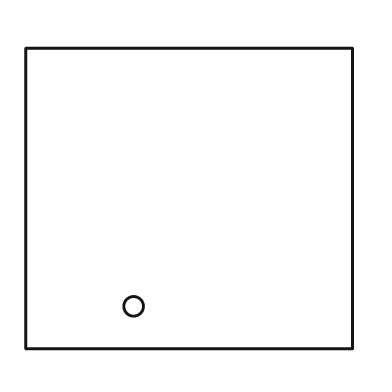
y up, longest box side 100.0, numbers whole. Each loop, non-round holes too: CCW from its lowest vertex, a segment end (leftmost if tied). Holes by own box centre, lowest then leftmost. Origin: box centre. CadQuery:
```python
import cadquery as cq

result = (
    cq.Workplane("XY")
    .moveTo(-50.0, -46.0)
    .lineTo(50.0, -46.0)
    .lineTo(50.0, 46.0)
    .lineTo(-50.0, 46.0)
    .close()
    .moveTo(-17.0, -33.0)
    .circle(3.0)
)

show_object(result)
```